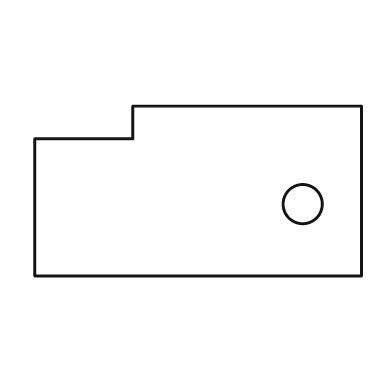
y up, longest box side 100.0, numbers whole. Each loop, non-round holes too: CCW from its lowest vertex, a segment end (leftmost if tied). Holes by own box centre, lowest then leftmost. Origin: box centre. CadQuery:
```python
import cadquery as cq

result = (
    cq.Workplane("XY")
    .moveTo(-50.0, -26.0)
    .lineTo(50.0, -26.0)
    .lineTo(50.0, 26.0)
    .lineTo(-20.0, 26.0)
    .lineTo(-20.0, 16.0)
    .lineTo(-50.0, 16.0)
    .close()
    .moveTo(32.0, -4.0)
    .circle(6.0)
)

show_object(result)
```